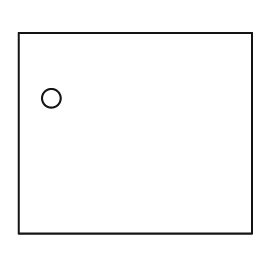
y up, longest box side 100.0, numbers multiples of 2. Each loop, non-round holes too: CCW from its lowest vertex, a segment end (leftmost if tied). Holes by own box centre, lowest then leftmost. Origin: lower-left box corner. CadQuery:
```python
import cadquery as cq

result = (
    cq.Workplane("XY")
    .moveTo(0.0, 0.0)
    .lineTo(100.0, 0.0)
    .lineTo(100.0, 86.0)
    .lineTo(0.0, 86.0)
    .close()
    .moveTo(14.0, 58.0)
    .circle(4.0)
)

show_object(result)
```